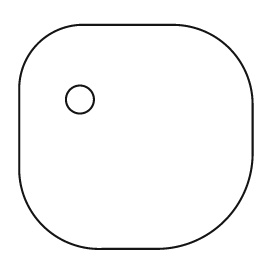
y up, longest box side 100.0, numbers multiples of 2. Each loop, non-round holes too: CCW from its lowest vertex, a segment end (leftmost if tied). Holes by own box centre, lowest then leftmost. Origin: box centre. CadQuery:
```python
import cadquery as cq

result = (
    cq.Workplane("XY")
    .moveTo(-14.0, -48.0)
    .lineTo(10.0, -48.0)
    .threePointArc((38.0, -36.0), (50.0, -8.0))
    .lineTo(50.0, 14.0)
    .threePointArc((40.0, 38.0), (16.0, 48.0))
    .lineTo(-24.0, 48.0)
    .threePointArc((-42.0, 40.0), (-50.0, 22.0))
    .lineTo(-50.0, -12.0)
    .threePointArc((-40.0, -38.0), (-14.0, -48.0))
    .close()
    .moveTo(-24.0, 16.0)
    .circle(6.0)
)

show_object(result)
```